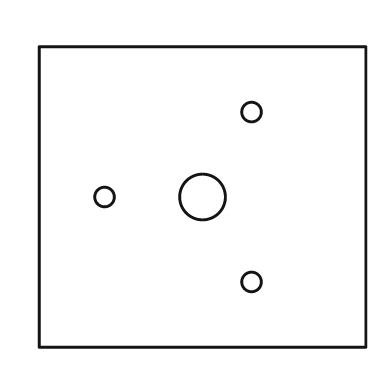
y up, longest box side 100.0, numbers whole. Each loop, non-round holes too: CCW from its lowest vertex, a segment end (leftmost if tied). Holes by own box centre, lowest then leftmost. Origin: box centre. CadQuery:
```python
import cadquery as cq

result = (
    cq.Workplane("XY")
    .moveTo(-50.0, -46.0)
    .lineTo(50.0, -46.0)
    .lineTo(50.0, 46.0)
    .lineTo(-50.0, 46.0)
    .close()
    .moveTo(15.0, -26.0)
    .circle(3.0)
    .moveTo(-30.0, 0.0)
    .circle(3.0)
    .moveTo(0.0, 0.0)
    .circle(7.0)
    .moveTo(15.0, 26.0)
    .circle(3.0)
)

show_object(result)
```